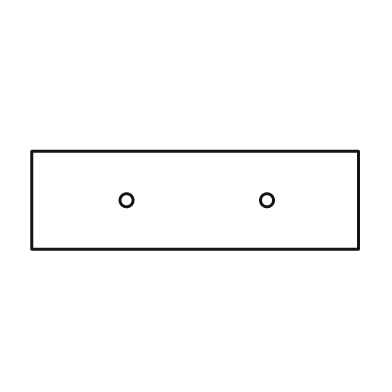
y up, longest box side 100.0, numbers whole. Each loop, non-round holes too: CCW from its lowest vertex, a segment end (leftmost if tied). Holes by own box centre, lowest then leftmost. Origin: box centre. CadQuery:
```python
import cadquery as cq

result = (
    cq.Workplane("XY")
    .moveTo(-50.0, -15.0)
    .lineTo(50.0, -15.0)
    .lineTo(50.0, 15.0)
    .lineTo(-50.0, 15.0)
    .close()
    .moveTo(-21.0, 0.0)
    .circle(2.0)
    .moveTo(22.0, 0.0)
    .circle(2.0)
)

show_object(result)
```